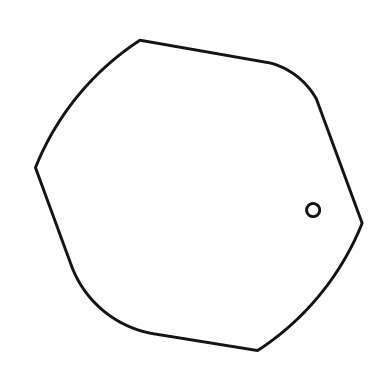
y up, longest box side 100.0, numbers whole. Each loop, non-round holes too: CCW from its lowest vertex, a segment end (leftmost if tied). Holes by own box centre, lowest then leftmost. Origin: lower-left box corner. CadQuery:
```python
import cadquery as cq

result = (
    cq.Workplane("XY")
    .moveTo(68.0, 0.0)
    .threePointArc((87.0, 17.0), (100.0, 39.0))
    .lineTo(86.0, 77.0)
    .threePointArc((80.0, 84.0), (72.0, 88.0))
    .lineTo(32.0, 95.0)
    .threePointArc((13.0, 78.0), (0.0, 56.0))
    .lineTo(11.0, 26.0)
    .threePointArc((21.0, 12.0), (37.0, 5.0))
    .close()
    .moveTo(85.0, 43.0)
    .circle(2.0)
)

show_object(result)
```